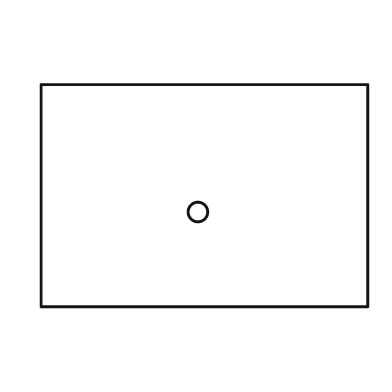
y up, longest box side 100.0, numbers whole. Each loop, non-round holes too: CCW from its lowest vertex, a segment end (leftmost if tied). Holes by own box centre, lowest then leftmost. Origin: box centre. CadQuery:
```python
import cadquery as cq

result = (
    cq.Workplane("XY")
    .moveTo(-50.0, -34.0)
    .lineTo(50.0, -34.0)
    .lineTo(50.0, 34.0)
    .lineTo(-50.0, 34.0)
    .close()
    .moveTo(-2.0, -5.0)
    .circle(3.0)
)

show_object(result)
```